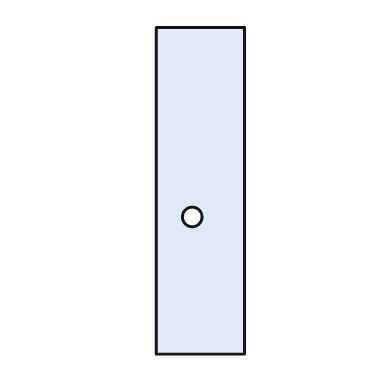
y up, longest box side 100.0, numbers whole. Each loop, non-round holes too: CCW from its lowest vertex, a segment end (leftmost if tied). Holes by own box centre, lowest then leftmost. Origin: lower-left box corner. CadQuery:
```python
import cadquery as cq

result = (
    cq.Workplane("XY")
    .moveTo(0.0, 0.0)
    .lineTo(27.0, 0.0)
    .lineTo(27.0, 100.0)
    .lineTo(0.0, 100.0)
    .close()
    .moveTo(11.0, 42.0)
    .circle(3.0)
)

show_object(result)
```